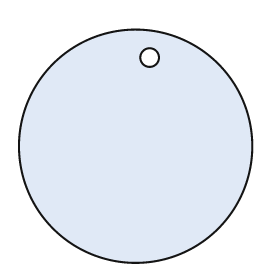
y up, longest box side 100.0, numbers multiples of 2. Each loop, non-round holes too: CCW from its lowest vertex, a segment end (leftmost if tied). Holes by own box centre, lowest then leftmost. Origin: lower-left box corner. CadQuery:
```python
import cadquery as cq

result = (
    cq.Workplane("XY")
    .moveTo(50.0, 50.0)
    .circle(50.0)
    .moveTo(56.0, 88.0)
    .circle(4.0)
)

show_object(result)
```